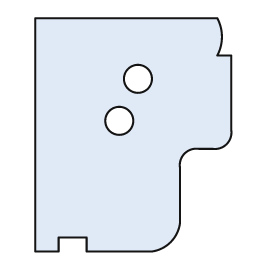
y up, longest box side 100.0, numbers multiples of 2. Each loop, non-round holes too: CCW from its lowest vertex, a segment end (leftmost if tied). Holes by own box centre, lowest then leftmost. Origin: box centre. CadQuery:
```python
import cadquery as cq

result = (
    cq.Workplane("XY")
    .moveTo(-42.0, -50.0)
    .lineTo(-32.0, -50.0)
    .lineTo(-32.0, -44.0)
    .lineTo(-20.0, -44.0)
    .lineTo(-20.0, -50.0)
    .lineTo(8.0, -50.0)
    .threePointArc((16.0, -46.0), (20.0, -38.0))
    .lineTo(20.0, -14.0)
    .threePointArc((22.0, -8.0), (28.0, -6.0))
    .lineTo(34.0, -6.0)
    .threePointArc((40.0, -4.0), (42.0, 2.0))
    .lineTo(42.0, 34.0)
    .lineTo(36.0, 34.0)
    .threePointArc((38.0, 42.0), (36.0, 50.0))
    .lineTo(-42.0, 50.0)
    .close()
    .moveTo(-6.0, 6.0)
    .circle(6.0)
    .moveTo(2.0, 24.0)
    .circle(6.0)
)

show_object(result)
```